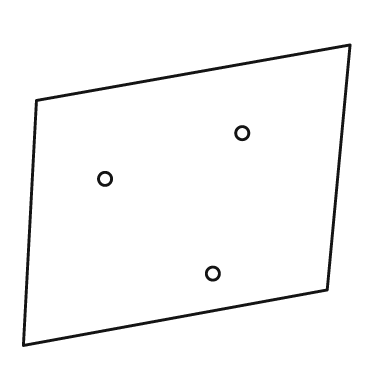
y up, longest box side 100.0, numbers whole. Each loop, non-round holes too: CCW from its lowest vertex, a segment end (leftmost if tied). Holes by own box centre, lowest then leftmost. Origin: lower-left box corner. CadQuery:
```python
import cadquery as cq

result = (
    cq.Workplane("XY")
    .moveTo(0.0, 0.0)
    .lineTo(93.0, 17.0)
    .lineTo(100.0, 92.0)
    .lineTo(4.0, 75.0)
    .close()
    .moveTo(58.0, 22.0)
    .circle(2.0)
    .moveTo(25.0, 51.0)
    .circle(2.0)
    .moveTo(67.0, 65.0)
    .circle(2.0)
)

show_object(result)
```